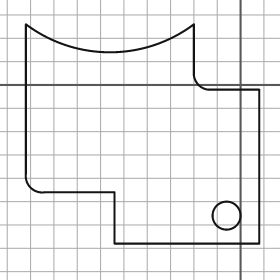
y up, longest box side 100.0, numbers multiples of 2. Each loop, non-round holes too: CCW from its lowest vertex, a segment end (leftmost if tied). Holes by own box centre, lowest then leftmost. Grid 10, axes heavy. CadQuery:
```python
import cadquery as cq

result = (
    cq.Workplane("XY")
    .moveTo(-54.0, -68.0)
    .lineTo(8.0, -68.0)
    .lineTo(8.0, -2.0)
    .lineTo(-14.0, -2.0)
    .threePointArc((-18.0, 0.0), (-20.0, 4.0))
    .lineTo(-20.0, 26.0)
    .threePointArc((-56.0, 14.0), (-92.0, 26.0))
    .lineTo(-92.0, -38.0)
    .threePointArc((-90.0, -44.0), (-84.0, -46.0))
    .lineTo(-54.0, -46.0)
    .close()
    .moveTo(-6.0, -56.0)
    .circle(6.0)
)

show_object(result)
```